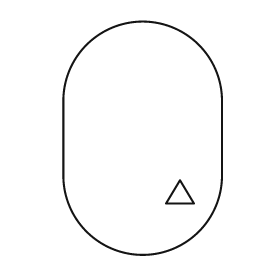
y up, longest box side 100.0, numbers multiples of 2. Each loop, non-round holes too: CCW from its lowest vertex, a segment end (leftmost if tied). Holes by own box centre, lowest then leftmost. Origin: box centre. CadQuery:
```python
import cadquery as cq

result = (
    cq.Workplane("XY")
    .moveTo(-34.0, -16.0)
    .threePointArc((0.0, -50.0), (34.0, -16.0))
    .lineTo(34.0, 16.0)
    .threePointArc((0.0, 50.0), (-34.0, 16.0))
    .close()
    .moveTo(10.0, -28.0)
    .lineTo(22.0, -28.0)
    .lineTo(16.0, -18.0)
    .close()
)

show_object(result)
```